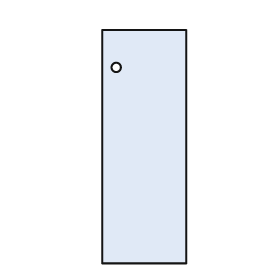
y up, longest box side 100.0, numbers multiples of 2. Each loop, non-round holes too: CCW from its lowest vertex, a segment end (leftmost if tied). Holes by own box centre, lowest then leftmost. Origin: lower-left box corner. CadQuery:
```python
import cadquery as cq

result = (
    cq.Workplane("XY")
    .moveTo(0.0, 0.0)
    .lineTo(36.0, 0.0)
    .lineTo(36.0, 100.0)
    .lineTo(0.0, 100.0)
    .close()
    .moveTo(6.0, 84.0)
    .circle(2.0)
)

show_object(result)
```